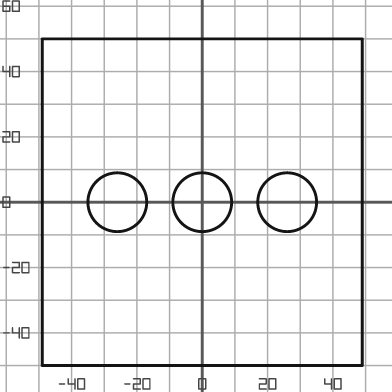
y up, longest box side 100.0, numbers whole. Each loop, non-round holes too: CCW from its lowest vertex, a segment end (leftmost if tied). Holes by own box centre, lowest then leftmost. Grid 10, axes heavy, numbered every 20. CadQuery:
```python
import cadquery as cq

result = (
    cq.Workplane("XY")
    .moveTo(-49.0, -50.0)
    .lineTo(49.0, -50.0)
    .lineTo(49.0, 50.0)
    .lineTo(-49.0, 50.0)
    .close()
    .moveTo(-26.0, 0.0)
    .circle(9.0)
    .moveTo(0.0, 0.0)
    .circle(9.0)
    .moveTo(26.0, 0.0)
    .circle(9.0)
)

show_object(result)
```